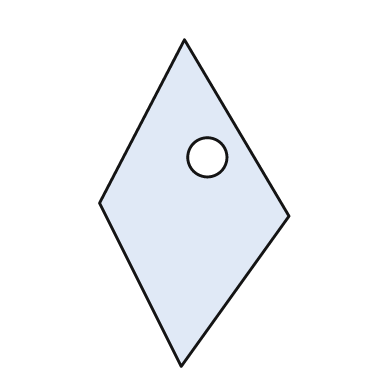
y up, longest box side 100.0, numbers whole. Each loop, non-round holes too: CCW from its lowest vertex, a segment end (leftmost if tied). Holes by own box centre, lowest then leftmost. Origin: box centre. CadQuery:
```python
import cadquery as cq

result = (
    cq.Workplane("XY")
    .moveTo(-4.0, -50.0)
    .lineTo(29.0, -4.0)
    .lineTo(-3.0, 50.0)
    .lineTo(-29.0, 0.0)
    .close()
    .moveTo(4.0, 14.0)
    .circle(6.0)
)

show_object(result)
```